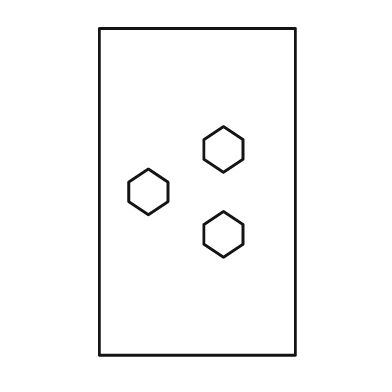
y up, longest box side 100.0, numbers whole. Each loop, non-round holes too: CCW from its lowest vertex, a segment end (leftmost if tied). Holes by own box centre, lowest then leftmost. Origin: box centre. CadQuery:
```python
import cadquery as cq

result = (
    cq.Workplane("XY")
    .moveTo(-30.0, -50.0)
    .lineTo(30.0, -50.0)
    .lineTo(30.0, 50.0)
    .lineTo(-30.0, 50.0)
    .close()
    .moveTo(8.0, -20.0)
    .lineTo(14.0, -16.0)
    .lineTo(14.0, -10.0)
    .lineTo(8.0, -6.0)
    .lineTo(2.0, -10.0)
    .lineTo(2.0, -16.0)
    .close()
    .moveTo(-15.0, -7.0)
    .lineTo(-9.0, -3.0)
    .lineTo(-9.0, 3.0)
    .lineTo(-15.0, 7.0)
    .lineTo(-21.0, 3.0)
    .lineTo(-21.0, -3.0)
    .close()
    .moveTo(8.0, 6.0)
    .lineTo(14.0, 10.0)
    .lineTo(14.0, 16.0)
    .lineTo(8.0, 20.0)
    .lineTo(2.0, 16.0)
    .lineTo(2.0, 10.0)
    .close()
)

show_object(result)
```